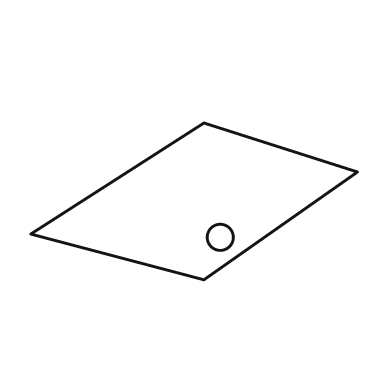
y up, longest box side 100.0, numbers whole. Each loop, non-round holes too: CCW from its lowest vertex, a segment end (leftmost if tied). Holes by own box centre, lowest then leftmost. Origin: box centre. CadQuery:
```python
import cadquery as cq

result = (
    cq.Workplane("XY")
    .moveTo(3.0, -24.0)
    .lineTo(50.0, 9.0)
    .lineTo(3.0, 24.0)
    .lineTo(-50.0, -10.0)
    .close()
    .moveTo(8.0, -11.0)
    .circle(4.0)
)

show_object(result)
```